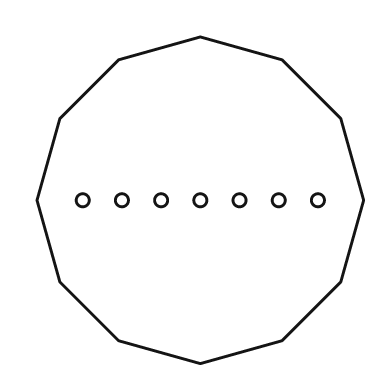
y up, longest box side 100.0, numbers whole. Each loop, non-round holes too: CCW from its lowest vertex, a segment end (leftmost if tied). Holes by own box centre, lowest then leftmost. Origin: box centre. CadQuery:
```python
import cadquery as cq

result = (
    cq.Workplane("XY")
    .moveTo(0.0, -50.0)
    .lineTo(25.0, -43.0)
    .lineTo(43.0, -25.0)
    .lineTo(50.0, 0.0)
    .lineTo(43.0, 25.0)
    .lineTo(25.0, 43.0)
    .lineTo(0.0, 50.0)
    .lineTo(-25.0, 43.0)
    .lineTo(-43.0, 25.0)
    .lineTo(-50.0, 0.0)
    .lineTo(-43.0, -25.0)
    .lineTo(-25.0, -43.0)
    .close()
    .moveTo(-36.0, 0.0)
    .circle(2.0)
    .moveTo(-24.0, 0.0)
    .circle(2.0)
    .moveTo(-12.0, 0.0)
    .circle(2.0)
    .moveTo(0.0, 0.0)
    .circle(2.0)
    .moveTo(12.0, 0.0)
    .circle(2.0)
    .moveTo(24.0, 0.0)
    .circle(2.0)
    .moveTo(36.0, 0.0)
    .circle(2.0)
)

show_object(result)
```